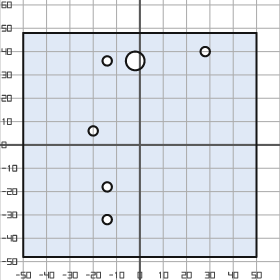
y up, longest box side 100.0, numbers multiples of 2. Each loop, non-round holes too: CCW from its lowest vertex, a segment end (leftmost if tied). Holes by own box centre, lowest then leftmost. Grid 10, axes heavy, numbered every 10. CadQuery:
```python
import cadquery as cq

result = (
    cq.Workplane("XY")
    .moveTo(-50.0, -48.0)
    .lineTo(50.0, -48.0)
    .lineTo(50.0, 48.0)
    .lineTo(-50.0, 48.0)
    .close()
    .moveTo(-14.0, -32.0)
    .circle(2.0)
    .moveTo(-14.0, -18.0)
    .circle(2.0)
    .moveTo(-20.0, 6.0)
    .circle(2.0)
    .moveTo(-14.0, 36.0)
    .circle(2.0)
    .moveTo(-2.0, 36.0)
    .circle(4.0)
    .moveTo(28.0, 40.0)
    .circle(2.0)
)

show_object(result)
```